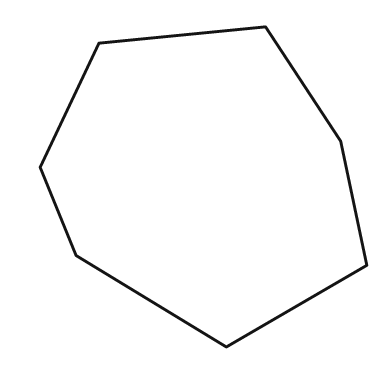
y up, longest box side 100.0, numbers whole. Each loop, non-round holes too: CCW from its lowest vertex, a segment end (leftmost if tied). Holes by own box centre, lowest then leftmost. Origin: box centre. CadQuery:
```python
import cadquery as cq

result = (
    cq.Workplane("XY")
    .moveTo(7.0, -49.0)
    .lineTo(50.0, -24.0)
    .lineTo(42.0, 14.0)
    .lineTo(19.0, 49.0)
    .lineTo(-32.0, 44.0)
    .lineTo(-50.0, 6.0)
    .lineTo(-39.0, -21.0)
    .close()
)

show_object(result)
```